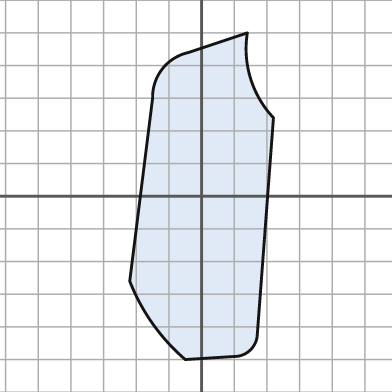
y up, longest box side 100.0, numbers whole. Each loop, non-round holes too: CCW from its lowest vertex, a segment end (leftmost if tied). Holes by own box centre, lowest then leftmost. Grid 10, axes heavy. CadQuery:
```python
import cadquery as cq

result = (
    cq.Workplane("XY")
    .moveTo(-5.0, -50.0)
    .lineTo(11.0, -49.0)
    .threePointArc((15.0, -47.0), (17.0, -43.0))
    .lineTo(22.0, 24.0)
    .threePointArc((15.0, 36.0), (14.0, 50.0))
    .lineTo(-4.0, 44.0)
    .threePointArc((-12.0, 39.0), (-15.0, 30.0))
    .lineTo(-22.0, -26.0)
    .threePointArc((-15.0, -39.0), (-5.0, -50.0))
    .close()
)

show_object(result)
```